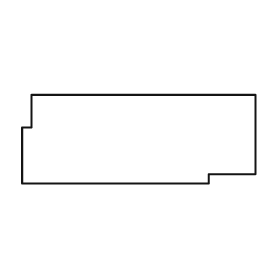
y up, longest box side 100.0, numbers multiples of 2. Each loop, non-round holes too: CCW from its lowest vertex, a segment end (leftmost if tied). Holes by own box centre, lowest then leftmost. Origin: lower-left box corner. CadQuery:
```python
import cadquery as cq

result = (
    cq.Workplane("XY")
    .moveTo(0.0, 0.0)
    .lineTo(80.0, 0.0)
    .lineTo(80.0, 4.0)
    .lineTo(100.0, 4.0)
    .lineTo(100.0, 38.0)
    .lineTo(4.0, 38.0)
    .lineTo(4.0, 24.0)
    .lineTo(0.0, 24.0)
    .close()
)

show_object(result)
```